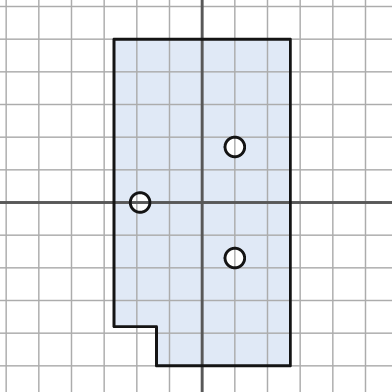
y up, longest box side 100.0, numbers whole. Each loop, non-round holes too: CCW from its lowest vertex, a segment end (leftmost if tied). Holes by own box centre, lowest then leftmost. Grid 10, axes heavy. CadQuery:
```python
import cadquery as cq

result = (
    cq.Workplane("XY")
    .moveTo(-14.0, -50.0)
    .lineTo(27.0, -50.0)
    .lineTo(27.0, 50.0)
    .lineTo(-27.0, 50.0)
    .lineTo(-27.0, -38.0)
    .lineTo(-14.0, -38.0)
    .close()
    .moveTo(10.0, -17.0)
    .circle(3.0)
    .moveTo(-19.0, 0.0)
    .circle(3.0)
    .moveTo(10.0, 17.0)
    .circle(3.0)
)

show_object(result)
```